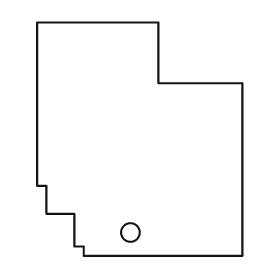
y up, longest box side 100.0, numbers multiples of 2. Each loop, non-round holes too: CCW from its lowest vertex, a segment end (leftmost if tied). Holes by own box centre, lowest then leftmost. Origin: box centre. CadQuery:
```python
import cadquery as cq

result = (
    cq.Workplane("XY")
    .moveTo(-24.0, -50.0)
    .lineTo(44.0, -50.0)
    .lineTo(44.0, 24.0)
    .lineTo(8.0, 24.0)
    .lineTo(8.0, 50.0)
    .lineTo(-44.0, 50.0)
    .lineTo(-44.0, -20.0)
    .lineTo(-40.0, -20.0)
    .lineTo(-40.0, -32.0)
    .lineTo(-28.0, -32.0)
    .lineTo(-28.0, -46.0)
    .lineTo(-24.0, -46.0)
    .close()
    .moveTo(-4.0, -40.0)
    .circle(4.0)
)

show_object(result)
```